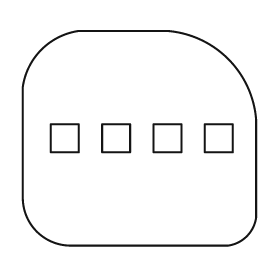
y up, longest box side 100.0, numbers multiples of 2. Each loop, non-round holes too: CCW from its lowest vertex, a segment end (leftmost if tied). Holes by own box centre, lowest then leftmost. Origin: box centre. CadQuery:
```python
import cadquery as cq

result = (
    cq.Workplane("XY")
    .moveTo(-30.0, -46.0)
    .lineTo(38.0, -46.0)
    .threePointArc((46.0, -42.0), (50.0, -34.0))
    .lineTo(50.0, 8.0)
    .threePointArc((38.0, 34.0), (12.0, 46.0))
    .lineTo(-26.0, 46.0)
    .threePointArc((-42.0, 38.0), (-50.0, 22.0))
    .lineTo(-50.0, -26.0)
    .threePointArc((-44.0, -40.0), (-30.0, -46.0))
    .close()
    .moveTo(-38.0, -6.0)
    .lineTo(-26.0, -6.0)
    .lineTo(-26.0, 6.0)
    .lineTo(-38.0, 6.0)
    .close()
    .moveTo(-16.0, -6.0)
    .lineTo(-4.0, -6.0)
    .lineTo(-4.0, 6.0)
    .lineTo(-16.0, 6.0)
    .close()
    .moveTo(6.0, -6.0)
    .lineTo(18.0, -6.0)
    .lineTo(18.0, 6.0)
    .lineTo(6.0, 6.0)
    .close()
    .moveTo(28.0, -6.0)
    .lineTo(40.0, -6.0)
    .lineTo(40.0, 6.0)
    .lineTo(28.0, 6.0)
    .close()
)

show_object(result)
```